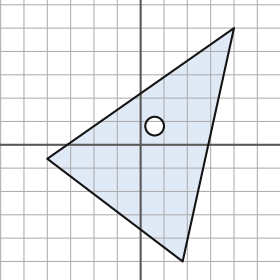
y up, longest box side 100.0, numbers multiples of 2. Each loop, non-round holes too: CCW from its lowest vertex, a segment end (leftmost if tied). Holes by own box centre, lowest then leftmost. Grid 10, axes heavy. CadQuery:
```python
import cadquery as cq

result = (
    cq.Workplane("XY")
    .moveTo(18.0, -50.0)
    .lineTo(40.0, 50.0)
    .lineTo(-40.0, -6.0)
    .close()
    .moveTo(6.0, 8.0)
    .circle(4.0)
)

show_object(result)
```